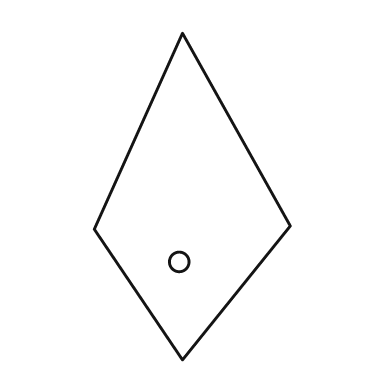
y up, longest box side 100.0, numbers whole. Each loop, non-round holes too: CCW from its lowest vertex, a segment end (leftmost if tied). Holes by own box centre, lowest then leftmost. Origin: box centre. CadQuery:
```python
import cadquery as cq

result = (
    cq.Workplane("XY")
    .moveTo(-3.0, -50.0)
    .lineTo(30.0, -9.0)
    .lineTo(-3.0, 50.0)
    .lineTo(-30.0, -10.0)
    .close()
    .moveTo(-4.0, -20.0)
    .circle(3.0)
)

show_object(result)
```